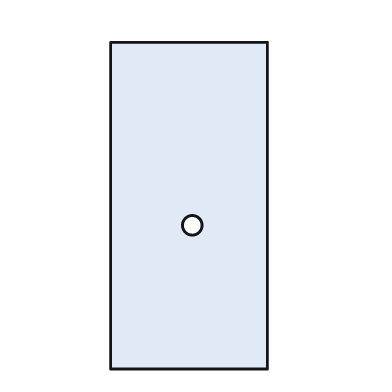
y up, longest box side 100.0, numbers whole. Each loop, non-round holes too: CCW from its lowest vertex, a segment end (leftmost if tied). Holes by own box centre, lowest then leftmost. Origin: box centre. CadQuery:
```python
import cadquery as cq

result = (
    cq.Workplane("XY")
    .moveTo(-24.0, -50.0)
    .lineTo(24.0, -50.0)
    .lineTo(24.0, 50.0)
    .lineTo(-24.0, 50.0)
    .close()
    .moveTo(1.0, -6.0)
    .circle(3.0)
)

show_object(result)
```